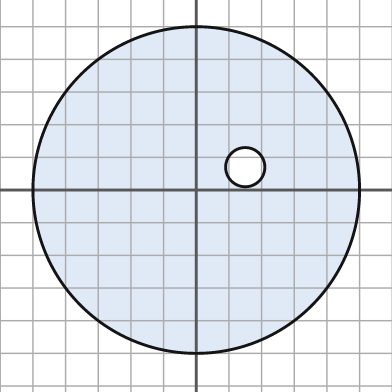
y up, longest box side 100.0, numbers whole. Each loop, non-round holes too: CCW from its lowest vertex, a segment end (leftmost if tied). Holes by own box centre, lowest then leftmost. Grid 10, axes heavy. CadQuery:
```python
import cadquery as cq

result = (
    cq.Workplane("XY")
    .moveTo(0.0, 0.0)
    .circle(50.0)
    .moveTo(15.0, 7.0)
    .circle(6.0)
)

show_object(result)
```